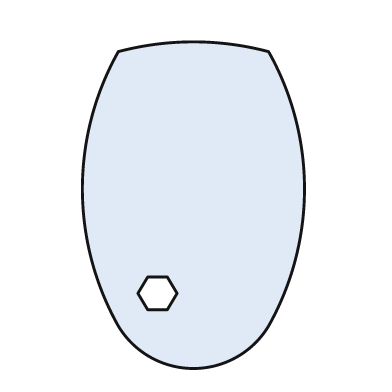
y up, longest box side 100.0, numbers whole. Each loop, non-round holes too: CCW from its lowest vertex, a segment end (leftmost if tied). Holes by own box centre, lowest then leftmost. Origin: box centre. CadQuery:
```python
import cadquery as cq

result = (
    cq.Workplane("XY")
    .moveTo(-23.0, -37.0)
    .threePointArc((0.0, -50.0), (23.0, -37.0))
    .threePointArc((34.0, 5.0), (23.0, 47.0))
    .threePointArc((0.0, 50.0), (-23.0, 47.0))
    .threePointArc((-34.0, 5.0), (-23.0, -37.0))
    .close()
    .moveTo(-14.0, -32.0)
    .lineTo(-8.0, -32.0)
    .lineTo(-5.0, -27.0)
    .lineTo(-8.0, -22.0)
    .lineTo(-14.0, -22.0)
    .lineTo(-17.0, -27.0)
    .close()
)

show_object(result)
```